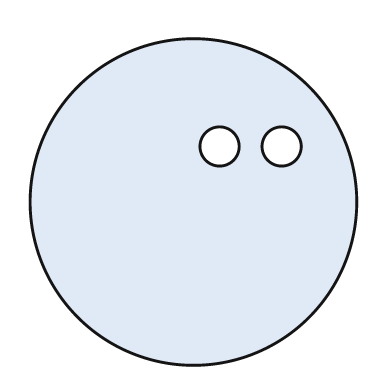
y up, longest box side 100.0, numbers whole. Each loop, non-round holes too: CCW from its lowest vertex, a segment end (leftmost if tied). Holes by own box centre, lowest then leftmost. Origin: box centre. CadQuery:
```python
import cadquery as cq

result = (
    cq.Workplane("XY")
    .moveTo(0.0, 0.0)
    .circle(50.0)
    .moveTo(8.0, 17.0)
    .circle(6.0)
    .moveTo(27.0, 17.0)
    .circle(6.0)
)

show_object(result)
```